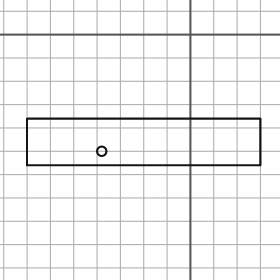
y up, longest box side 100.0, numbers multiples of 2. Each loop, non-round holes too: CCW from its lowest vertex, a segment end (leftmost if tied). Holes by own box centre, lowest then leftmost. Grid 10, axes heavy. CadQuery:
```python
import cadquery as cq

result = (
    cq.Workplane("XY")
    .moveTo(-70.0, -56.0)
    .lineTo(30.0, -56.0)
    .lineTo(30.0, -36.0)
    .lineTo(-70.0, -36.0)
    .close()
    .moveTo(-38.0, -50.0)
    .circle(2.0)
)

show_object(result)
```